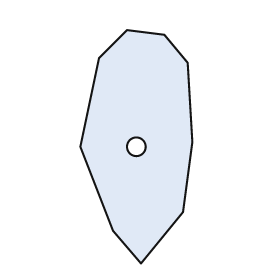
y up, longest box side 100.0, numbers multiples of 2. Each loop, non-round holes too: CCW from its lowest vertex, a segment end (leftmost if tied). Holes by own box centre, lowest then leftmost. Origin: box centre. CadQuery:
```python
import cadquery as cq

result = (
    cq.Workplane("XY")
    .moveTo(2.0, -50.0)
    .lineTo(20.0, -28.0)
    .lineTo(24.0, 2.0)
    .lineTo(22.0, 36.0)
    .lineTo(12.0, 48.0)
    .lineTo(-4.0, 50.0)
    .lineTo(-16.0, 38.0)
    .lineTo(-24.0, 0.0)
    .lineTo(-10.0, -36.0)
    .close()
    .moveTo(0.0, 0.0)
    .circle(4.0)
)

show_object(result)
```